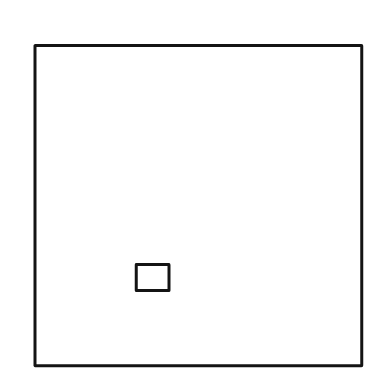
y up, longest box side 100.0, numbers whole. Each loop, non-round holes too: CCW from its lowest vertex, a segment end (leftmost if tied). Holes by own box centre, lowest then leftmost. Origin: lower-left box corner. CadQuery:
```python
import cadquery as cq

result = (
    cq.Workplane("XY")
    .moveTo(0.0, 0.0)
    .lineTo(100.0, 0.0)
    .lineTo(100.0, 98.0)
    .lineTo(0.0, 98.0)
    .close()
    .moveTo(31.0, 23.0)
    .lineTo(41.0, 23.0)
    .lineTo(41.0, 31.0)
    .lineTo(31.0, 31.0)
    .close()
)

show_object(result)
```